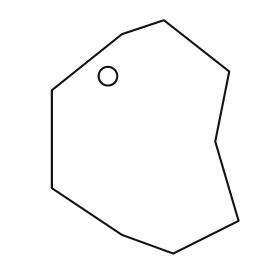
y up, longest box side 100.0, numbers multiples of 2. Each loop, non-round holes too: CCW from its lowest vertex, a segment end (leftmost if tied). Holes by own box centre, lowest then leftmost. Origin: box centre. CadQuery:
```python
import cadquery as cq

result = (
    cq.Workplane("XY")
    .moveTo(12.0, -50.0)
    .lineTo(40.0, -36.0)
    .lineTo(30.0, -2.0)
    .lineTo(36.0, 28.0)
    .lineTo(8.0, 50.0)
    .lineTo(-10.0, 44.0)
    .lineTo(-40.0, 20.0)
    .lineTo(-40.0, -22.0)
    .lineTo(-10.0, -42.0)
    .close()
    .moveTo(-16.0, 26.0)
    .circle(4.0)
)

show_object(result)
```